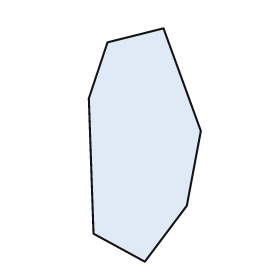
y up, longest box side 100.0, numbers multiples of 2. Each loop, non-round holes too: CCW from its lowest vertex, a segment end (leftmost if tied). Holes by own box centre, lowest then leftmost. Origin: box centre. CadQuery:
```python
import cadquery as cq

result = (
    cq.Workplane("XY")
    .moveTo(0.0, -50.0)
    .lineTo(18.0, -26.0)
    .lineTo(24.0, 6.0)
    .lineTo(8.0, 50.0)
    .lineTo(-16.0, 44.0)
    .lineTo(-24.0, 20.0)
    .lineTo(-22.0, -38.0)
    .close()
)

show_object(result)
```